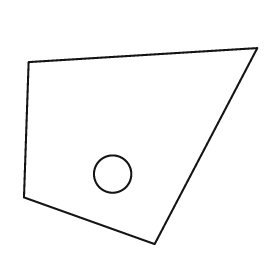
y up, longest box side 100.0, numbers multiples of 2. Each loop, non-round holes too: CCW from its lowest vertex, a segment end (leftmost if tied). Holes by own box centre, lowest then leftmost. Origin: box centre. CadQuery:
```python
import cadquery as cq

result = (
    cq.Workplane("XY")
    .moveTo(6.0, -42.0)
    .lineTo(50.0, 42.0)
    .lineTo(-48.0, 36.0)
    .lineTo(-50.0, -22.0)
    .close()
    .moveTo(-12.0, -12.0)
    .circle(8.0)
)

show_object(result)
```